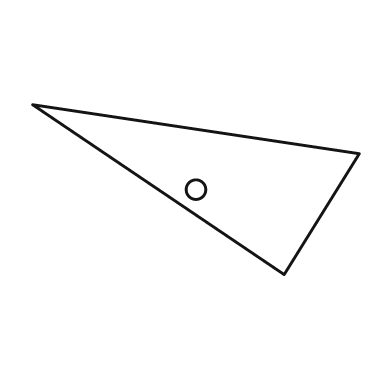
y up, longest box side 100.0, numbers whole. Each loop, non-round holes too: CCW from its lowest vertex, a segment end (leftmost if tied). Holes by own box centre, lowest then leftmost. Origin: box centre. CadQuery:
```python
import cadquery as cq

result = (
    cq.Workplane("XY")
    .moveTo(27.0, -26.0)
    .lineTo(50.0, 11.0)
    .lineTo(-50.0, 26.0)
    .close()
    .moveTo(0.0, 0.0)
    .circle(3.0)
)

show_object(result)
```